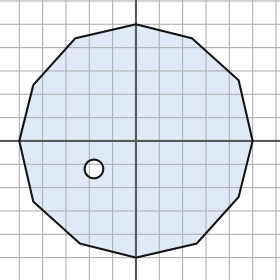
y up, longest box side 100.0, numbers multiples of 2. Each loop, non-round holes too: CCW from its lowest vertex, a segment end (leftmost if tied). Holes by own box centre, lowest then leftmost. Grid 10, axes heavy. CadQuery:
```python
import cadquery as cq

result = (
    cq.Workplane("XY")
    .moveTo(0.0, -50.0)
    .lineTo(26.0, -44.0)
    .lineTo(44.0, -24.0)
    .lineTo(50.0, 0.0)
    .lineTo(44.0, 26.0)
    .lineTo(24.0, 44.0)
    .lineTo(0.0, 50.0)
    .lineTo(-26.0, 44.0)
    .lineTo(-44.0, 24.0)
    .lineTo(-50.0, 0.0)
    .lineTo(-44.0, -26.0)
    .lineTo(-24.0, -44.0)
    .close()
    .moveTo(-18.0, -12.0)
    .circle(4.0)
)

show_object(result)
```